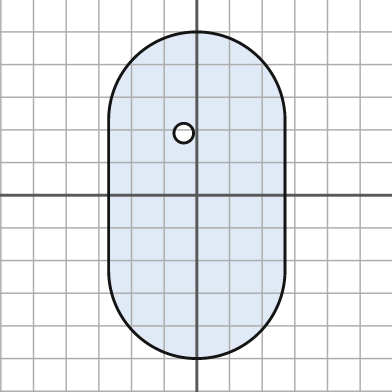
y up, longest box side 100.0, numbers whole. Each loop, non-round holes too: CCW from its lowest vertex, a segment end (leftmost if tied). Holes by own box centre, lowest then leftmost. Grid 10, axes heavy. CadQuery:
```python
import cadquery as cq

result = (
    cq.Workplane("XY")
    .moveTo(-27.0, -23.0)
    .threePointArc((0.0, -50.0), (27.0, -23.0))
    .lineTo(27.0, 23.0)
    .threePointArc((0.0, 50.0), (-27.0, 23.0))
    .close()
    .moveTo(-4.0, 19.0)
    .circle(3.0)
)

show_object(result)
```